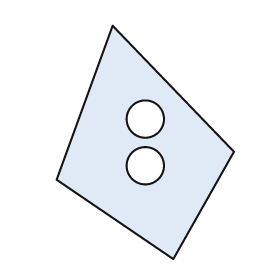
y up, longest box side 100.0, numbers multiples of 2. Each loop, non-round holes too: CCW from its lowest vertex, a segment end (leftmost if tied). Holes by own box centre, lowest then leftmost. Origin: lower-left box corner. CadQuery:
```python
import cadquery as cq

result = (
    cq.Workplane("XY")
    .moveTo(50.0, 0.0)
    .lineTo(76.0, 46.0)
    .lineTo(24.0, 100.0)
    .lineTo(0.0, 34.0)
    .close()
    .moveTo(38.0, 40.0)
    .circle(8.0)
    .moveTo(38.0, 60.0)
    .circle(8.0)
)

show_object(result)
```